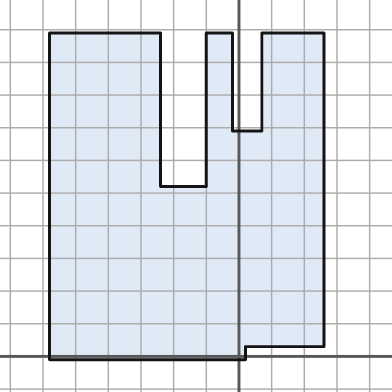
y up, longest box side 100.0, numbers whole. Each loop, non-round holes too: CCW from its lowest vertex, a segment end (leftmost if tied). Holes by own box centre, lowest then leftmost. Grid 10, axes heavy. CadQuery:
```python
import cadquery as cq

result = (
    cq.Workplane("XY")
    .moveTo(-58.0, -1.0)
    .lineTo(2.0, -1.0)
    .lineTo(2.0, 3.0)
    .lineTo(26.0, 3.0)
    .lineTo(26.0, 99.0)
    .lineTo(7.0, 99.0)
    .lineTo(7.0, 69.0)
    .lineTo(-2.0, 69.0)
    .lineTo(-2.0, 99.0)
    .lineTo(-10.0, 99.0)
    .lineTo(-10.0, 52.0)
    .lineTo(-24.0, 52.0)
    .lineTo(-24.0, 99.0)
    .lineTo(-58.0, 99.0)
    .close()
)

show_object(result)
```